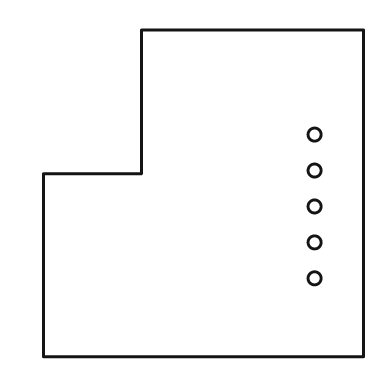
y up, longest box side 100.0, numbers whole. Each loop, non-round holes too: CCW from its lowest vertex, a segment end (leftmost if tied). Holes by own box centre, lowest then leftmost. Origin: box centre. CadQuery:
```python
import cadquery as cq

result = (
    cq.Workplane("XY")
    .moveTo(-49.0, -50.0)
    .lineTo(49.0, -50.0)
    .lineTo(49.0, 50.0)
    .lineTo(-19.0, 50.0)
    .lineTo(-19.0, 6.0)
    .lineTo(-49.0, 6.0)
    .close()
    .moveTo(34.0, -26.0)
    .circle(2.0)
    .moveTo(34.0, -15.0)
    .circle(2.0)
    .moveTo(34.0, -4.0)
    .circle(2.0)
    .moveTo(34.0, 7.0)
    .circle(2.0)
    .moveTo(34.0, 18.0)
    .circle(2.0)
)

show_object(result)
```